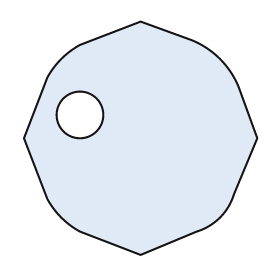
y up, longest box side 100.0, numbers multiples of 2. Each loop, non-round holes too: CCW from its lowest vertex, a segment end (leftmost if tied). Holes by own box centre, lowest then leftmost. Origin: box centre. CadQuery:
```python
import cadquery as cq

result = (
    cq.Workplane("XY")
    .moveTo(0.0, -50.0)
    .lineTo(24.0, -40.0)
    .threePointArc((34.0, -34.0), (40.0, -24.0))
    .lineTo(50.0, 0.0)
    .lineTo(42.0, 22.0)
    .threePointArc((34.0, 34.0), (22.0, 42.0))
    .lineTo(0.0, 50.0)
    .lineTo(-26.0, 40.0)
    .threePointArc((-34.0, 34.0), (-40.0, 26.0))
    .lineTo(-50.0, 0.0)
    .lineTo(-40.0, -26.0)
    .threePointArc((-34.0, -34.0), (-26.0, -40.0))
    .close()
    .moveTo(-26.0, 10.0)
    .circle(10.0)
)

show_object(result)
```